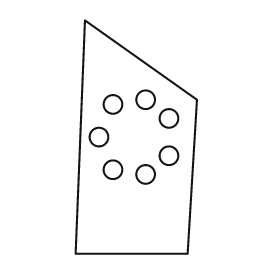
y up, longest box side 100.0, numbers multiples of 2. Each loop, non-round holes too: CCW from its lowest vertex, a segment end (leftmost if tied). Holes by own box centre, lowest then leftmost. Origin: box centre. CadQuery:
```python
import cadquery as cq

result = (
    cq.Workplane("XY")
    .moveTo(-26.0, -50.0)
    .lineTo(22.0, -50.0)
    .lineTo(26.0, 16.0)
    .lineTo(-22.0, 50.0)
    .close()
    .moveTo(4.0, -16.0)
    .circle(4.0)
    .moveTo(-10.0, -14.0)
    .circle(4.0)
    .moveTo(14.0, -8.0)
    .circle(4.0)
    .moveTo(-16.0, 0.0)
    .circle(4.0)
    .moveTo(14.0, 8.0)
    .circle(4.0)
    .moveTo(-10.0, 14.0)
    .circle(4.0)
    .moveTo(4.0, 16.0)
    .circle(4.0)
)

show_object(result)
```